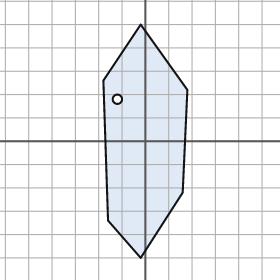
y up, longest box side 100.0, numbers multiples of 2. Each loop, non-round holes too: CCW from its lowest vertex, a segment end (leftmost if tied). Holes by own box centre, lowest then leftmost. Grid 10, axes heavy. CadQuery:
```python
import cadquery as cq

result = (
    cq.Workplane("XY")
    .moveTo(-2.0, -50.0)
    .lineTo(16.0, -22.0)
    .lineTo(18.0, 22.0)
    .lineTo(-2.0, 50.0)
    .lineTo(-18.0, 26.0)
    .lineTo(-16.0, -34.0)
    .close()
    .moveTo(-12.0, 18.0)
    .circle(2.0)
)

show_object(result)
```